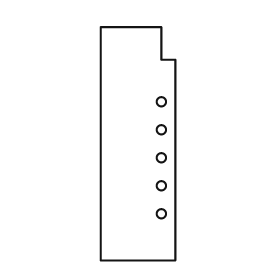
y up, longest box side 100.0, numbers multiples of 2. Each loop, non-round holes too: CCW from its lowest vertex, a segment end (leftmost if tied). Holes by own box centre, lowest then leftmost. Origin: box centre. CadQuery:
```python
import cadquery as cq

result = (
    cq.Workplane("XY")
    .moveTo(-16.0, -50.0)
    .lineTo(16.0, -50.0)
    .lineTo(16.0, 36.0)
    .lineTo(10.0, 36.0)
    .lineTo(10.0, 50.0)
    .lineTo(-16.0, 50.0)
    .close()
    .moveTo(10.0, -30.0)
    .circle(2.0)
    .moveTo(10.0, -18.0)
    .circle(2.0)
    .moveTo(10.0, -6.0)
    .circle(2.0)
    .moveTo(10.0, 6.0)
    .circle(2.0)
    .moveTo(10.0, 18.0)
    .circle(2.0)
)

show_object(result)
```